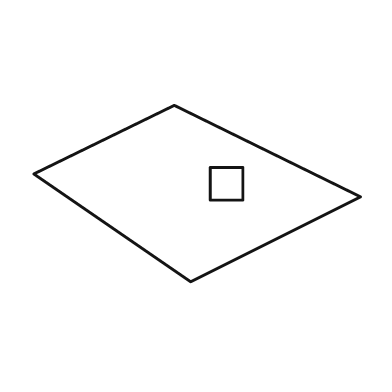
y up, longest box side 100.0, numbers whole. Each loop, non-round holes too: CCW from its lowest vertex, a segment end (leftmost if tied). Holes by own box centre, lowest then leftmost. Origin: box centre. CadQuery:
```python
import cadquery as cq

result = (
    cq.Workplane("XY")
    .moveTo(-2.0, -27.0)
    .lineTo(50.0, -1.0)
    .lineTo(-7.0, 27.0)
    .lineTo(-50.0, 6.0)
    .close()
    .moveTo(4.0, -2.0)
    .lineTo(14.0, -2.0)
    .lineTo(14.0, 8.0)
    .lineTo(4.0, 8.0)
    .close()
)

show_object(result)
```